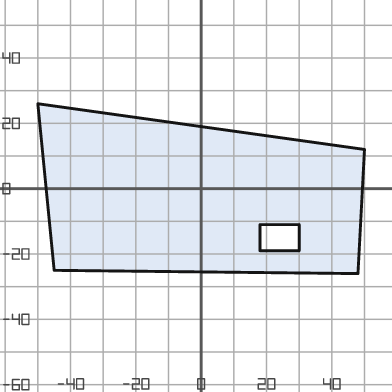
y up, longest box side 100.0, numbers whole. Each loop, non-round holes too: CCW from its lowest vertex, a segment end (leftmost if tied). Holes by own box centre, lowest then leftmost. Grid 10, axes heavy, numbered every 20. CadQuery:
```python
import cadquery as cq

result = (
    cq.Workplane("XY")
    .moveTo(48.0, -26.0)
    .lineTo(50.0, 12.0)
    .lineTo(-50.0, 26.0)
    .lineTo(-45.0, -25.0)
    .close()
    .moveTo(18.0, -19.0)
    .lineTo(30.0, -19.0)
    .lineTo(30.0, -11.0)
    .lineTo(18.0, -11.0)
    .close()
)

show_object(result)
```